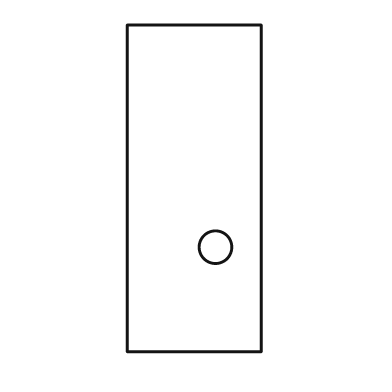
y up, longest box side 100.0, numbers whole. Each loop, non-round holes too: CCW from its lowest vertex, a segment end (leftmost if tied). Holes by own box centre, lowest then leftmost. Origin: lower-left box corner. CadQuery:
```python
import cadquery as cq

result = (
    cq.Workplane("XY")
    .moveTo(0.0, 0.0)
    .lineTo(41.0, 0.0)
    .lineTo(41.0, 100.0)
    .lineTo(0.0, 100.0)
    .close()
    .moveTo(27.0, 32.0)
    .circle(5.0)
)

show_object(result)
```